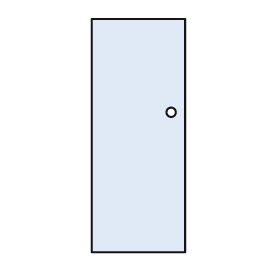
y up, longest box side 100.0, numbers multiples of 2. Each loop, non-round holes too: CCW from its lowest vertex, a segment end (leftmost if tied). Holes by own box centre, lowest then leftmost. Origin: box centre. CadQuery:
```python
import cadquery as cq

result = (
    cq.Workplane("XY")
    .moveTo(-20.0, -50.0)
    .lineTo(20.0, -50.0)
    .lineTo(20.0, 50.0)
    .lineTo(-20.0, 50.0)
    .close()
    .moveTo(14.0, 10.0)
    .circle(2.0)
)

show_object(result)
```